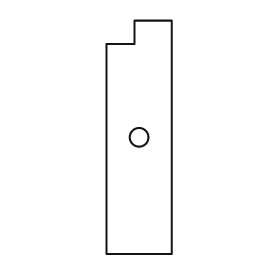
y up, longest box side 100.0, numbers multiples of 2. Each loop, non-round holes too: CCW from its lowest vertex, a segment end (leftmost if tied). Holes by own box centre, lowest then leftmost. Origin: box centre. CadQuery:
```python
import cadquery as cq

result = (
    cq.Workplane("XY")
    .moveTo(-14.0, -50.0)
    .lineTo(14.0, -50.0)
    .lineTo(14.0, 50.0)
    .lineTo(-2.0, 50.0)
    .lineTo(-2.0, 40.0)
    .lineTo(-14.0, 40.0)
    .close()
    .moveTo(0.0, 0.0)
    .circle(4.0)
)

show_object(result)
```